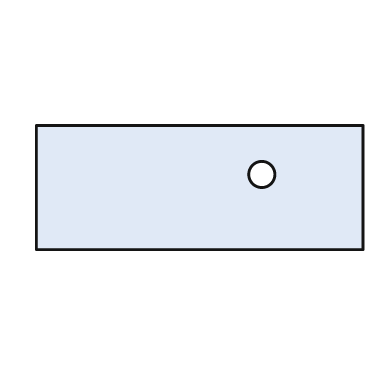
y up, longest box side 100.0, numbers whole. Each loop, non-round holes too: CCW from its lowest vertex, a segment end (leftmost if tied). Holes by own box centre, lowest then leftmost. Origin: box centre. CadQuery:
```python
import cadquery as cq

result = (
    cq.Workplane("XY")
    .moveTo(-50.0, -19.0)
    .lineTo(50.0, -19.0)
    .lineTo(50.0, 19.0)
    .lineTo(-50.0, 19.0)
    .close()
    .moveTo(19.0, 4.0)
    .circle(4.0)
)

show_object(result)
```